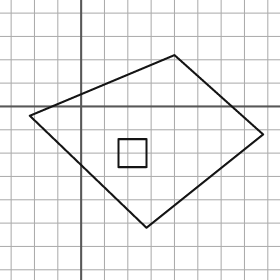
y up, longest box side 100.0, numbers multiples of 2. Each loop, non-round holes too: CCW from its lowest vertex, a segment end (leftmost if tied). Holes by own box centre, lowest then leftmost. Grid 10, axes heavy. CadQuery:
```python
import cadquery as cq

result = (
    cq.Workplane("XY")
    .moveTo(28.0, -52.0)
    .lineTo(78.0, -12.0)
    .lineTo(40.0, 22.0)
    .lineTo(-22.0, -4.0)
    .close()
    .moveTo(16.0, -26.0)
    .lineTo(28.0, -26.0)
    .lineTo(28.0, -14.0)
    .lineTo(16.0, -14.0)
    .close()
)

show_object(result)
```